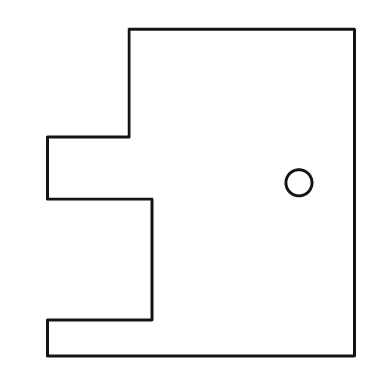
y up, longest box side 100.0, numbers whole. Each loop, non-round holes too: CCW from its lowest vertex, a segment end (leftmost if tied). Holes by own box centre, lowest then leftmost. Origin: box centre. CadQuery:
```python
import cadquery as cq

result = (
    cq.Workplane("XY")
    .moveTo(-47.0, -50.0)
    .lineTo(47.0, -50.0)
    .lineTo(47.0, 50.0)
    .lineTo(-22.0, 50.0)
    .lineTo(-22.0, 17.0)
    .lineTo(-47.0, 17.0)
    .lineTo(-47.0, -2.0)
    .lineTo(-15.0, -2.0)
    .lineTo(-15.0, -39.0)
    .lineTo(-47.0, -39.0)
    .close()
    .moveTo(30.0, 3.0)
    .circle(4.0)
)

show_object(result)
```